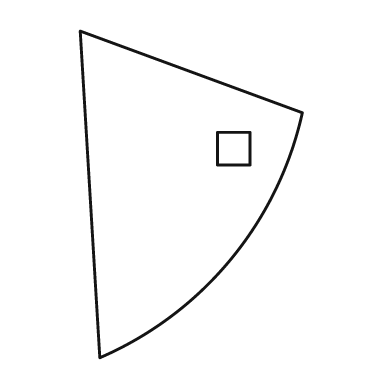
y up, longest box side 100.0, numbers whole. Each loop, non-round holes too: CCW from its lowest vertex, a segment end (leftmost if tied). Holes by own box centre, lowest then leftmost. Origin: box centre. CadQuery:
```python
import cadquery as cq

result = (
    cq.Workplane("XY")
    .moveTo(-28.0, -50.0)
    .threePointArc((12.0, -20.0), (34.0, 25.0))
    .lineTo(-34.0, 50.0)
    .close()
    .moveTo(8.0, 9.0)
    .lineTo(18.0, 9.0)
    .lineTo(18.0, 19.0)
    .lineTo(8.0, 19.0)
    .close()
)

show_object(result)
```